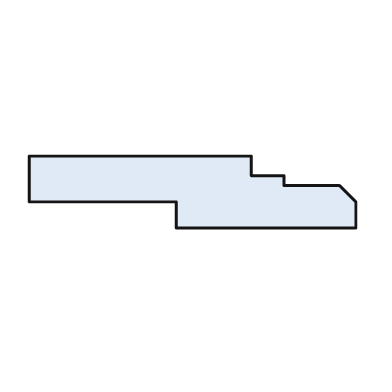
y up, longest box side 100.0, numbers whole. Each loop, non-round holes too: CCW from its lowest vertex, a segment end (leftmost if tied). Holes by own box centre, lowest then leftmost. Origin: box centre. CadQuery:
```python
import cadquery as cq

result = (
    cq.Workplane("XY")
    .moveTo(-5.0, -11.0)
    .lineTo(50.0, -11.0)
    .lineTo(50.0, -3.0)
    .lineTo(45.0, 2.0)
    .lineTo(28.0, 2.0)
    .lineTo(28.0, 5.0)
    .lineTo(18.0, 5.0)
    .lineTo(18.0, 11.0)
    .lineTo(-50.0, 11.0)
    .lineTo(-50.0, -3.0)
    .lineTo(-5.0, -3.0)
    .close()
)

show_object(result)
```